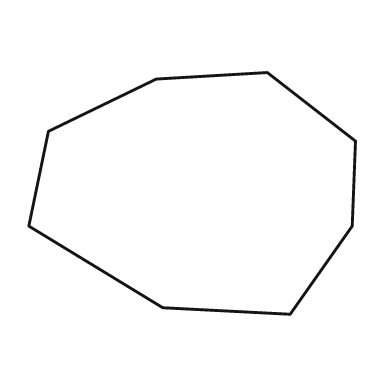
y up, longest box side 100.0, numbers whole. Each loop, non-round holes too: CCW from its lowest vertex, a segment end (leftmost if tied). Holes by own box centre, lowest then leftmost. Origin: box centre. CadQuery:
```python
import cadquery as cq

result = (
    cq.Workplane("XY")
    .moveTo(30.0, -37.0)
    .lineTo(49.0, -10.0)
    .lineTo(50.0, 16.0)
    .lineTo(23.0, 37.0)
    .lineTo(-11.0, 35.0)
    .lineTo(-44.0, 19.0)
    .lineTo(-50.0, -10.0)
    .lineTo(-9.0, -35.0)
    .close()
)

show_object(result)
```